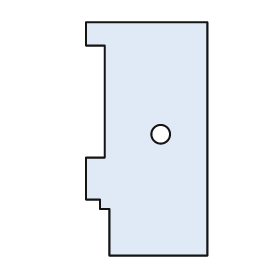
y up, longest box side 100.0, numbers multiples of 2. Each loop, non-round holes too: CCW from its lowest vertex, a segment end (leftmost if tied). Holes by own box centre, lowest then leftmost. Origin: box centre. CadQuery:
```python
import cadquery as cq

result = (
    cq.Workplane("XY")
    .moveTo(-16.0, -50.0)
    .lineTo(26.0, -50.0)
    .lineTo(26.0, 50.0)
    .lineTo(-26.0, 50.0)
    .lineTo(-26.0, 40.0)
    .lineTo(-18.0, 40.0)
    .lineTo(-18.0, -8.0)
    .lineTo(-26.0, -8.0)
    .lineTo(-26.0, -26.0)
    .lineTo(-20.0, -26.0)
    .lineTo(-20.0, -30.0)
    .lineTo(-16.0, -30.0)
    .close()
    .moveTo(6.0, 2.0)
    .circle(4.0)
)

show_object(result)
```